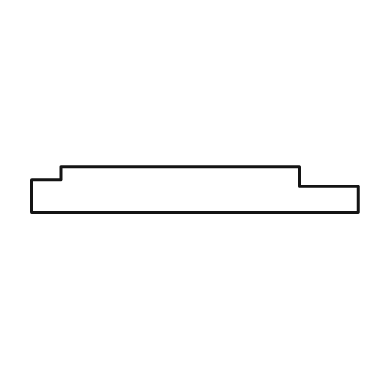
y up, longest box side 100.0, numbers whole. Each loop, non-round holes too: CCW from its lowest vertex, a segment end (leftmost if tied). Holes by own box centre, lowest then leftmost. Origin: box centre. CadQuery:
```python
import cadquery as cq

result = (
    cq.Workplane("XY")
    .moveTo(-50.0, -7.0)
    .lineTo(50.0, -7.0)
    .lineTo(50.0, 1.0)
    .lineTo(32.0, 1.0)
    .lineTo(32.0, 7.0)
    .lineTo(-41.0, 7.0)
    .lineTo(-41.0, 3.0)
    .lineTo(-50.0, 3.0)
    .close()
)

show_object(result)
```